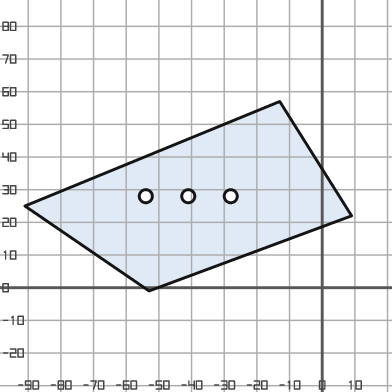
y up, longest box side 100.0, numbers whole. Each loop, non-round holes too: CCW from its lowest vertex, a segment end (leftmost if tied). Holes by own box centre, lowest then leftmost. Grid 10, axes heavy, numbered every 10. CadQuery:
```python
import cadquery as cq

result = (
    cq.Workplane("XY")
    .moveTo(-53.0, -1.0)
    .lineTo(9.0, 22.0)
    .lineTo(-13.0, 57.0)
    .lineTo(-91.0, 25.0)
    .close()
    .moveTo(-54.0, 28.0)
    .circle(2.0)
    .moveTo(-41.0, 28.0)
    .circle(2.0)
    .moveTo(-28.0, 28.0)
    .circle(2.0)
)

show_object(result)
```